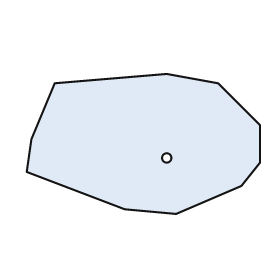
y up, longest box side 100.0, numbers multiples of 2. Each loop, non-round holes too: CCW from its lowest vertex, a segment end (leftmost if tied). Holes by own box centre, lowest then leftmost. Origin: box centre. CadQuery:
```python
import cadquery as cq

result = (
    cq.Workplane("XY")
    .moveTo(14.0, -30.0)
    .lineTo(42.0, -18.0)
    .lineTo(50.0, -8.0)
    .lineTo(50.0, 8.0)
    .lineTo(32.0, 26.0)
    .lineTo(10.0, 30.0)
    .lineTo(-38.0, 26.0)
    .lineTo(-48.0, 2.0)
    .lineTo(-50.0, -12.0)
    .lineTo(-8.0, -28.0)
    .close()
    .moveTo(10.0, -6.0)
    .circle(2.0)
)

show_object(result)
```